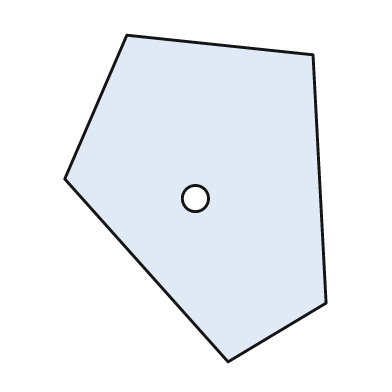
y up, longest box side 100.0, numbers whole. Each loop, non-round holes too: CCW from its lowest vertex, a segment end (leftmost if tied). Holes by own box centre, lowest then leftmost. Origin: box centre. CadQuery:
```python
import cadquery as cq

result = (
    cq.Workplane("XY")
    .moveTo(10.0, -50.0)
    .lineTo(40.0, -32.0)
    .lineTo(36.0, 44.0)
    .lineTo(-21.0, 50.0)
    .lineTo(-40.0, 6.0)
    .close()
    .moveTo(0.0, 0.0)
    .circle(4.0)
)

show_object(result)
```